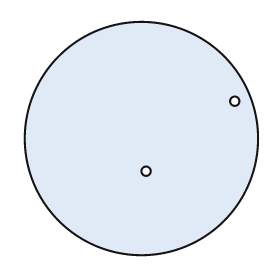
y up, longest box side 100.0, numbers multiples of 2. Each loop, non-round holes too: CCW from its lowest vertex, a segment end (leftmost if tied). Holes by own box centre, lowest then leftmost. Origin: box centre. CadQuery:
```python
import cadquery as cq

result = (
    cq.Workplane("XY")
    .moveTo(0.0, 0.0)
    .circle(50.0)
    .moveTo(2.0, -14.0)
    .circle(2.0)
    .moveTo(40.0, 16.0)
    .circle(2.0)
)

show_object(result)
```